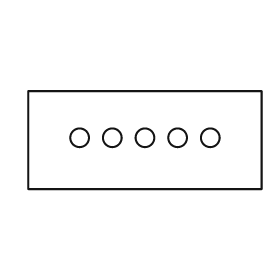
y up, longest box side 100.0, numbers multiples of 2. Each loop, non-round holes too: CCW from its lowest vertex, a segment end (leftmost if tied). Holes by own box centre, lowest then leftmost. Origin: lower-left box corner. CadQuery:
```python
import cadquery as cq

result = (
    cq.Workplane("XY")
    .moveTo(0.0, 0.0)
    .lineTo(100.0, 0.0)
    .lineTo(100.0, 42.0)
    .lineTo(0.0, 42.0)
    .close()
    .moveTo(22.0, 22.0)
    .circle(4.0)
    .moveTo(36.0, 22.0)
    .circle(4.0)
    .moveTo(50.0, 22.0)
    .circle(4.0)
    .moveTo(64.0, 22.0)
    .circle(4.0)
    .moveTo(78.0, 22.0)
    .circle(4.0)
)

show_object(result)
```